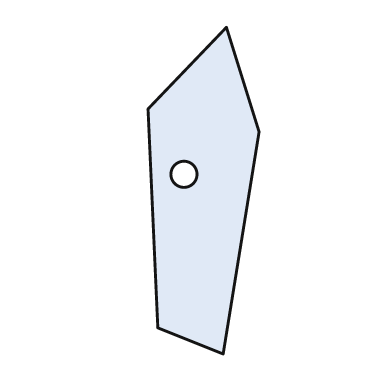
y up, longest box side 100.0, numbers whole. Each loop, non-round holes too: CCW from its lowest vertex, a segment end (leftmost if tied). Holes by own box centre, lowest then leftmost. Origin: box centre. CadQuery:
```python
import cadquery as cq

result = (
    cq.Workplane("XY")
    .moveTo(6.0, -50.0)
    .lineTo(17.0, 18.0)
    .lineTo(7.0, 50.0)
    .lineTo(-17.0, 25.0)
    .lineTo(-14.0, -42.0)
    .close()
    .moveTo(-6.0, 5.0)
    .circle(4.0)
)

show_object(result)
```